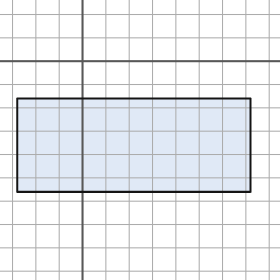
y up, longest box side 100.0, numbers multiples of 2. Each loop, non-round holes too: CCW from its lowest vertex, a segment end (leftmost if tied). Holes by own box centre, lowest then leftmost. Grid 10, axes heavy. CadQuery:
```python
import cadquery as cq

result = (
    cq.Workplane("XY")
    .moveTo(-28.0, -56.0)
    .lineTo(72.0, -56.0)
    .lineTo(72.0, -16.0)
    .lineTo(-28.0, -16.0)
    .close()
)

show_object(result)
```